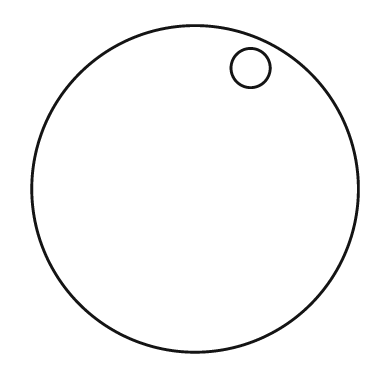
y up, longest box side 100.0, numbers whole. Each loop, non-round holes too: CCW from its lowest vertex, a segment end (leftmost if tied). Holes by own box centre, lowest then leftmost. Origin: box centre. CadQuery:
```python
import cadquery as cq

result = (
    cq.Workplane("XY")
    .moveTo(0.0, 0.0)
    .circle(50.0)
    .moveTo(17.0, 37.0)
    .circle(6.0)
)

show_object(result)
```